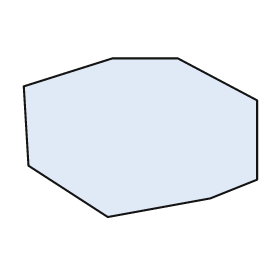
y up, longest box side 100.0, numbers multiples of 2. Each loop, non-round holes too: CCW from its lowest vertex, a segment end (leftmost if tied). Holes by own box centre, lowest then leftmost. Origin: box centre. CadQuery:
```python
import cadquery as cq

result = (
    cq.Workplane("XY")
    .moveTo(-14.0, -34.0)
    .lineTo(30.0, -26.0)
    .lineTo(50.0, -18.0)
    .lineTo(50.0, 16.0)
    .lineTo(16.0, 34.0)
    .lineTo(-12.0, 34.0)
    .lineTo(-50.0, 22.0)
    .lineTo(-48.0, -12.0)
    .close()
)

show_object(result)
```